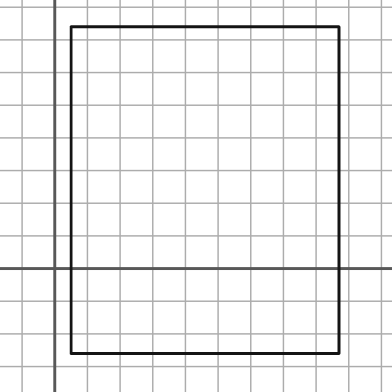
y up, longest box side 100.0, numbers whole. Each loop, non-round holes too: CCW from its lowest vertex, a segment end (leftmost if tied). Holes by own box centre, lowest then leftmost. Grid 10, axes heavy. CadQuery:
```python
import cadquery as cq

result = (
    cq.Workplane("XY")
    .moveTo(5.0, -26.0)
    .lineTo(87.0, -26.0)
    .lineTo(87.0, 74.0)
    .lineTo(5.0, 74.0)
    .close()
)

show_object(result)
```